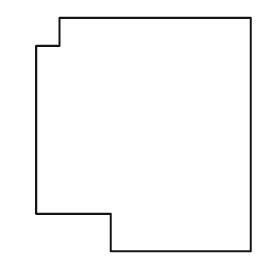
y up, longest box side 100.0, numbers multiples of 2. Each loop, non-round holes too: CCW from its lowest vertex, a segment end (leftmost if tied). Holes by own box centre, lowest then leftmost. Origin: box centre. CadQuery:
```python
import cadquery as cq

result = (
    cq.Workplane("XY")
    .moveTo(-14.0, -50.0)
    .lineTo(46.0, -50.0)
    .lineTo(46.0, 50.0)
    .lineTo(-36.0, 50.0)
    .lineTo(-36.0, 38.0)
    .lineTo(-46.0, 38.0)
    .lineTo(-46.0, -34.0)
    .lineTo(-14.0, -34.0)
    .close()
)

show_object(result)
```